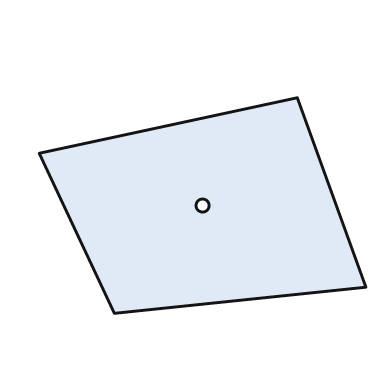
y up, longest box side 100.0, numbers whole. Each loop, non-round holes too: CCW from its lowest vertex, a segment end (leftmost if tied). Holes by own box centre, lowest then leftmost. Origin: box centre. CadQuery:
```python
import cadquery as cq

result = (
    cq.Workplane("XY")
    .moveTo(-27.0, -33.0)
    .lineTo(50.0, -25.0)
    .lineTo(29.0, 33.0)
    .lineTo(-50.0, 16.0)
    .close()
    .moveTo(0.0, 0.0)
    .circle(2.0)
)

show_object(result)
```